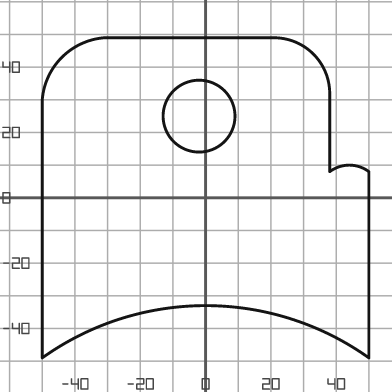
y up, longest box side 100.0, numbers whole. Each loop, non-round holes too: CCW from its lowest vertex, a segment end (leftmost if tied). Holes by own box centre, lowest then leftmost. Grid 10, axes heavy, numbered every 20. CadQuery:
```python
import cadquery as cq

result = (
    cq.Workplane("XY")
    .moveTo(-50.0, -49.0)
    .threePointArc((0.0, -33.0), (50.0, -49.0))
    .lineTo(50.0, 8.0)
    .threePointArc((44.0, 10.0), (38.0, 8.0))
    .lineTo(38.0, 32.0)
    .threePointArc((33.0, 44.0), (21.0, 49.0))
    .lineTo(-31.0, 49.0)
    .threePointArc((-44.0, 43.0), (-50.0, 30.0))
    .close()
    .moveTo(-2.0, 25.0)
    .circle(11.0)
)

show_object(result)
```